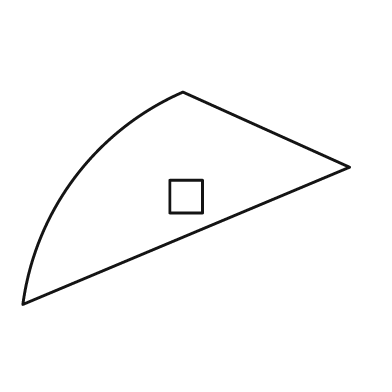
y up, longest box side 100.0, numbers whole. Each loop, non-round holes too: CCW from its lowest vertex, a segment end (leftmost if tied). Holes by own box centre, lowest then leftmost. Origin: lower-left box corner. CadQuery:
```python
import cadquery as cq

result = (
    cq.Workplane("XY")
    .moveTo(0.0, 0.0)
    .lineTo(100.0, 42.0)
    .lineTo(49.0, 65.0)
    .threePointArc((16.0, 39.0), (0.0, 0.0))
    .close()
    .moveTo(45.0, 28.0)
    .lineTo(55.0, 28.0)
    .lineTo(55.0, 38.0)
    .lineTo(45.0, 38.0)
    .close()
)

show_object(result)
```